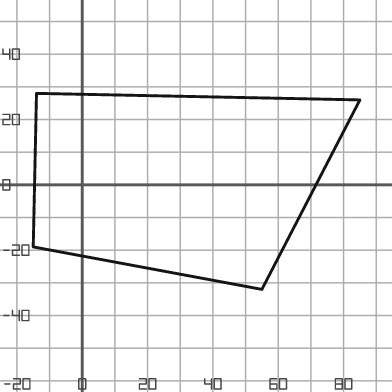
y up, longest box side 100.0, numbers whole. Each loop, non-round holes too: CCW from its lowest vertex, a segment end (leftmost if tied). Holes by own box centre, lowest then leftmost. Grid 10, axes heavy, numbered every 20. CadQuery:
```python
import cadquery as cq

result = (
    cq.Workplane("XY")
    .moveTo(55.0, -32.0)
    .lineTo(85.0, 26.0)
    .lineTo(-14.0, 28.0)
    .lineTo(-15.0, -19.0)
    .close()
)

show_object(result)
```